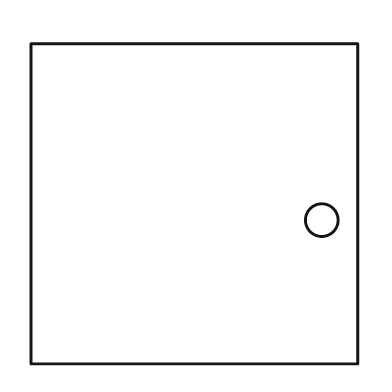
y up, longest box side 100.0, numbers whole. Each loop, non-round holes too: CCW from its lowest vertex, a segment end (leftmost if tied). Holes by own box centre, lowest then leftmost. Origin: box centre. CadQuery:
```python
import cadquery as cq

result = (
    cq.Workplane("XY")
    .moveTo(-50.0, -49.0)
    .lineTo(50.0, -49.0)
    .lineTo(50.0, 49.0)
    .lineTo(-50.0, 49.0)
    .close()
    .moveTo(39.0, -5.0)
    .circle(5.0)
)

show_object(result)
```